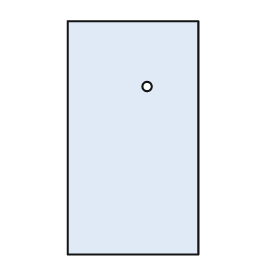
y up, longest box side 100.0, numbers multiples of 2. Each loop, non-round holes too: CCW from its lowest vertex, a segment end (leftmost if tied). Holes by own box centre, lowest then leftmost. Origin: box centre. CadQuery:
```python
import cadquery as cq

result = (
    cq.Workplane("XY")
    .moveTo(-28.0, -50.0)
    .lineTo(28.0, -50.0)
    .lineTo(28.0, 50.0)
    .lineTo(-28.0, 50.0)
    .close()
    .moveTo(6.0, 22.0)
    .circle(2.0)
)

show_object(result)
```